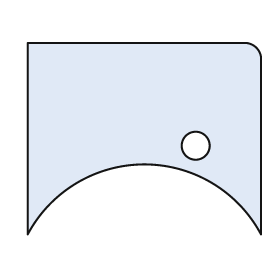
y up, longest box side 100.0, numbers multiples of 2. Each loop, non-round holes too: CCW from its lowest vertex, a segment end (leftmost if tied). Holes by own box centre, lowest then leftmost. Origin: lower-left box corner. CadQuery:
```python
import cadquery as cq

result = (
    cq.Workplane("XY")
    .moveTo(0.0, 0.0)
    .threePointArc((50.0, 30.0), (100.0, 0.0))
    .lineTo(100.0, 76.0)
    .threePointArc((98.0, 80.0), (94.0, 82.0))
    .lineTo(0.0, 82.0)
    .close()
    .moveTo(72.0, 38.0)
    .circle(6.0)
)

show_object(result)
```